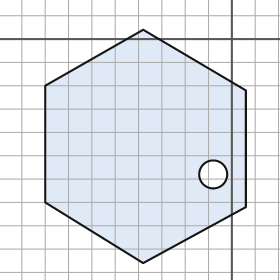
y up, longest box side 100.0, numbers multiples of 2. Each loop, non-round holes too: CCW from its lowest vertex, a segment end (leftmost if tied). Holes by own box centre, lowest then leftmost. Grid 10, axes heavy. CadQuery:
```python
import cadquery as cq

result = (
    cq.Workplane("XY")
    .moveTo(-38.0, -96.0)
    .lineTo(6.0, -72.0)
    .lineTo(6.0, -22.0)
    .lineTo(-38.0, 4.0)
    .lineTo(-80.0, -20.0)
    .lineTo(-80.0, -70.0)
    .close()
    .moveTo(-8.0, -58.0)
    .circle(6.0)
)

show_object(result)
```